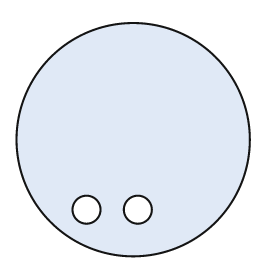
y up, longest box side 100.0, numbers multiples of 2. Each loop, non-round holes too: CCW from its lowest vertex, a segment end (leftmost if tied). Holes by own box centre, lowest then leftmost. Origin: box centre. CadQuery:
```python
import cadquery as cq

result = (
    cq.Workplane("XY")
    .moveTo(0.0, 0.0)
    .circle(50.0)
    .moveTo(-20.0, -30.0)
    .circle(6.0)
    .moveTo(2.0, -30.0)
    .circle(6.0)
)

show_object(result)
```